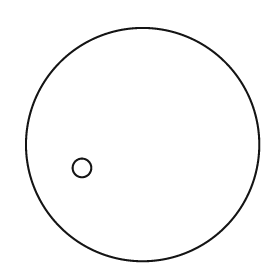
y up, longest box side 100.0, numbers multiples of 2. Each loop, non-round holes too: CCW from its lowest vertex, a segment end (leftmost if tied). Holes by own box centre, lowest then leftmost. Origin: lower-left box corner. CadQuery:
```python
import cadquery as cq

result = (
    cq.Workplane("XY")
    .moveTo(50.0, 50.0)
    .circle(50.0)
    .moveTo(24.0, 40.0)
    .circle(4.0)
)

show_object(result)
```